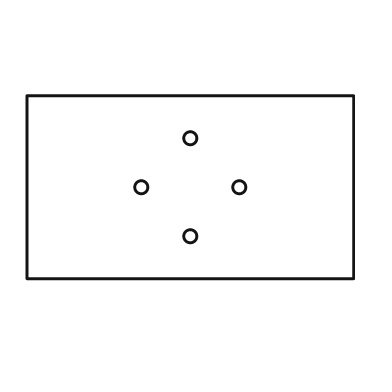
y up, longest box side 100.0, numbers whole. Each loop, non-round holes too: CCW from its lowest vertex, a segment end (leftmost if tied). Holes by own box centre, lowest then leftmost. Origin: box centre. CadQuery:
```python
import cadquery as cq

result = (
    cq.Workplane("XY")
    .moveTo(-50.0, -28.0)
    .lineTo(50.0, -28.0)
    .lineTo(50.0, 28.0)
    .lineTo(-50.0, 28.0)
    .close()
    .moveTo(0.0, -15.0)
    .circle(2.0)
    .moveTo(-15.0, 0.0)
    .circle(2.0)
    .moveTo(15.0, 0.0)
    .circle(2.0)
    .moveTo(0.0, 15.0)
    .circle(2.0)
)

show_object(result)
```